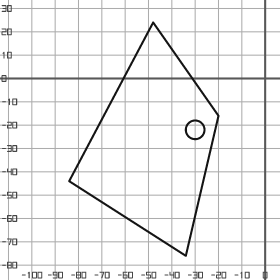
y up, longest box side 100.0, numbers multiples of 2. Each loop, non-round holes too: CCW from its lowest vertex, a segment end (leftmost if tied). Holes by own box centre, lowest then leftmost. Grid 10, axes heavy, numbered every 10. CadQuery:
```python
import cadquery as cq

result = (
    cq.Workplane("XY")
    .moveTo(-34.0, -76.0)
    .lineTo(-20.0, -16.0)
    .lineTo(-48.0, 24.0)
    .lineTo(-84.0, -44.0)
    .close()
    .moveTo(-30.0, -22.0)
    .circle(4.0)
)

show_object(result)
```